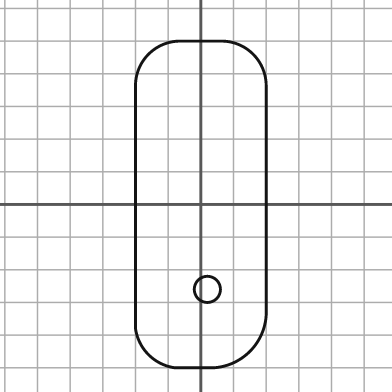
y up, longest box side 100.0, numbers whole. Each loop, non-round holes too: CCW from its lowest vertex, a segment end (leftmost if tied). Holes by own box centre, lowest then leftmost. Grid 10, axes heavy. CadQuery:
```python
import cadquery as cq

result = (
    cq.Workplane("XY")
    .moveTo(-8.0, -50.0)
    .lineTo(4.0, -50.0)
    .threePointArc((15.0, -45.0), (20.0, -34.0))
    .lineTo(20.0, 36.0)
    .threePointArc((16.0, 46.0), (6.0, 50.0))
    .lineTo(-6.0, 50.0)
    .threePointArc((-16.0, 46.0), (-20.0, 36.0))
    .lineTo(-20.0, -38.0)
    .threePointArc((-16.0, -46.0), (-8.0, -50.0))
    .close()
    .moveTo(2.0, -26.0)
    .circle(4.0)
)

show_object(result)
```